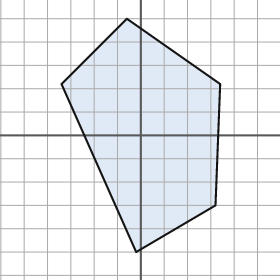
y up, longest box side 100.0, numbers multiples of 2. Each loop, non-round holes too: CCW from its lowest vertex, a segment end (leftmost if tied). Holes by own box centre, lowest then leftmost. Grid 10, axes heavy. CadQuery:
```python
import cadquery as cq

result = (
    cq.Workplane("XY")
    .moveTo(-2.0, -50.0)
    .lineTo(32.0, -30.0)
    .lineTo(34.0, 22.0)
    .lineTo(-6.0, 50.0)
    .lineTo(-34.0, 22.0)
    .close()
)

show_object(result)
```